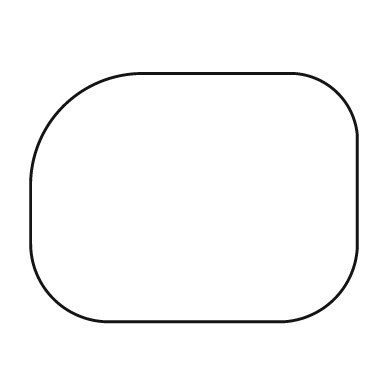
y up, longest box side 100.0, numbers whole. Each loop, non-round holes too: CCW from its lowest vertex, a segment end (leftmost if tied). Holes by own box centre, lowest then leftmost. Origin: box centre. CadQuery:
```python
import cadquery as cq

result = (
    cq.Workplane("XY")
    .moveTo(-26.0, -38.0)
    .lineTo(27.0, -38.0)
    .threePointArc((43.0, -31.0), (50.0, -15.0))
    .lineTo(50.0, 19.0)
    .threePointArc((44.0, 32.0), (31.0, 38.0))
    .lineTo(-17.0, 38.0)
    .threePointArc((-40.0, 28.0), (-50.0, 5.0))
    .lineTo(-50.0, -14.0)
    .threePointArc((-43.0, -31.0), (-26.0, -38.0))
    .close()
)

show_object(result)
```